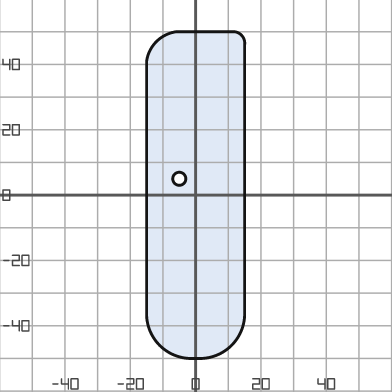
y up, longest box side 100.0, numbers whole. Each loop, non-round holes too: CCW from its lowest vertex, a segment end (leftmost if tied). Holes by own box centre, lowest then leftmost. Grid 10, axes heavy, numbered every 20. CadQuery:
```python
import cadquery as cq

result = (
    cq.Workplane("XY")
    .moveTo(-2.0, -50.0)
    .lineTo(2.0, -50.0)
    .threePointArc((11.0, -46.0), (15.0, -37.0))
    .lineTo(15.0, 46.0)
    .threePointArc((14.0, 49.0), (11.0, 50.0))
    .lineTo(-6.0, 50.0)
    .threePointArc((-12.0, 47.0), (-15.0, 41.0))
    .lineTo(-15.0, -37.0)
    .threePointArc((-11.0, -46.0), (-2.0, -50.0))
    .close()
    .moveTo(-5.0, 5.0)
    .circle(2.0)
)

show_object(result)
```